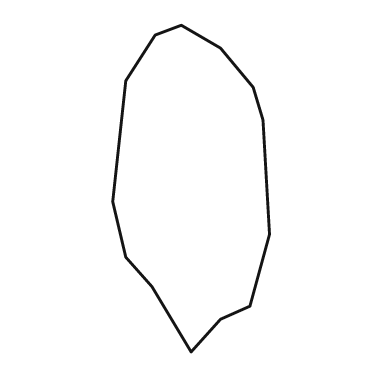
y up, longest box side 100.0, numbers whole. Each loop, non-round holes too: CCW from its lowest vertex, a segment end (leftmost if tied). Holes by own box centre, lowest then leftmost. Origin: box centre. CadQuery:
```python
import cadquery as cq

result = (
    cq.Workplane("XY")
    .moveTo(0.0, -50.0)
    .lineTo(9.0, -40.0)
    .lineTo(18.0, -36.0)
    .lineTo(24.0, -14.0)
    .lineTo(22.0, 21.0)
    .lineTo(19.0, 31.0)
    .lineTo(9.0, 43.0)
    .lineTo(-3.0, 50.0)
    .lineTo(-11.0, 47.0)
    .lineTo(-20.0, 33.0)
    .lineTo(-24.0, -4.0)
    .lineTo(-20.0, -21.0)
    .lineTo(-12.0, -30.0)
    .close()
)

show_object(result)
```